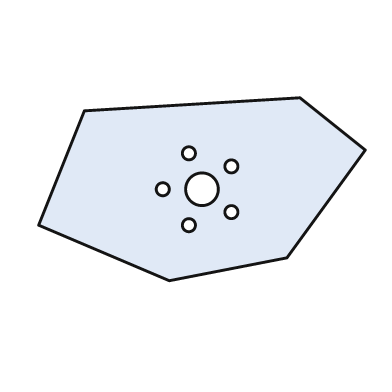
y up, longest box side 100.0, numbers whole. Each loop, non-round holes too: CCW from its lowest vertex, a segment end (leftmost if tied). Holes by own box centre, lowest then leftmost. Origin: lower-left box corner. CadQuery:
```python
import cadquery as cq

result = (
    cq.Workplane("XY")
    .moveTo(40.0, 0.0)
    .lineTo(76.0, 7.0)
    .lineTo(100.0, 40.0)
    .lineTo(80.0, 56.0)
    .lineTo(14.0, 52.0)
    .lineTo(0.0, 17.0)
    .close()
    .moveTo(46.0, 17.0)
    .circle(2.0)
    .moveTo(59.0, 21.0)
    .circle(2.0)
    .moveTo(38.0, 28.0)
    .circle(2.0)
    .moveTo(50.0, 28.0)
    .circle(5.0)
    .moveTo(59.0, 35.0)
    .circle(2.0)
    .moveTo(46.0, 39.0)
    .circle(2.0)
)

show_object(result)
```